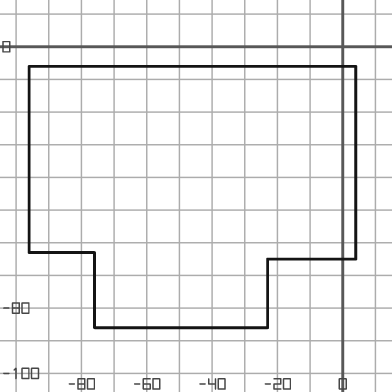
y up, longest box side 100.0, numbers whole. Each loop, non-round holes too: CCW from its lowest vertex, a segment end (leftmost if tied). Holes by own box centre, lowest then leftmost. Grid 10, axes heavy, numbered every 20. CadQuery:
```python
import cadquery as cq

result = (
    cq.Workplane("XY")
    .moveTo(-76.0, -86.0)
    .lineTo(-23.0, -86.0)
    .lineTo(-23.0, -65.0)
    .lineTo(4.0, -65.0)
    .lineTo(4.0, -6.0)
    .lineTo(-96.0, -6.0)
    .lineTo(-96.0, -63.0)
    .lineTo(-76.0, -63.0)
    .close()
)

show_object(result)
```